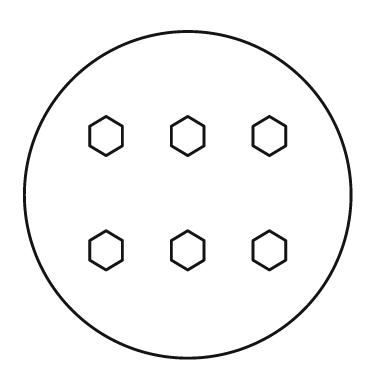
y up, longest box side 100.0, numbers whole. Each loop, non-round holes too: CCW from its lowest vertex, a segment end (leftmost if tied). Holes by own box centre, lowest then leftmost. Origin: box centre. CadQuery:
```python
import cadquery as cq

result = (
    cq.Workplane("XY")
    .moveTo(0.0, 0.0)
    .circle(50.0)
    .moveTo(-25.0, -23.0)
    .lineTo(-20.0, -20.0)
    .lineTo(-20.0, -14.0)
    .lineTo(-25.0, -11.0)
    .lineTo(-30.0, -14.0)
    .lineTo(-30.0, -20.0)
    .close()
    .moveTo(0.0, -23.0)
    .lineTo(5.0, -20.0)
    .lineTo(5.0, -14.0)
    .lineTo(0.0, -11.0)
    .lineTo(-5.0, -14.0)
    .lineTo(-5.0, -20.0)
    .close()
    .moveTo(25.0, -23.0)
    .lineTo(30.0, -20.0)
    .lineTo(30.0, -14.0)
    .lineTo(25.0, -11.0)
    .lineTo(20.0, -14.0)
    .lineTo(20.0, -20.0)
    .close()
    .moveTo(-25.0, 12.0)
    .lineTo(-20.0, 15.0)
    .lineTo(-20.0, 21.0)
    .lineTo(-25.0, 24.0)
    .lineTo(-30.0, 21.0)
    .lineTo(-30.0, 15.0)
    .close()
    .moveTo(0.0, 12.0)
    .lineTo(5.0, 15.0)
    .lineTo(5.0, 21.0)
    .lineTo(0.0, 24.0)
    .lineTo(-5.0, 21.0)
    .lineTo(-5.0, 15.0)
    .close()
    .moveTo(25.0, 12.0)
    .lineTo(30.0, 15.0)
    .lineTo(30.0, 21.0)
    .lineTo(25.0, 24.0)
    .lineTo(20.0, 21.0)
    .lineTo(20.0, 15.0)
    .close()
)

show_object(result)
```